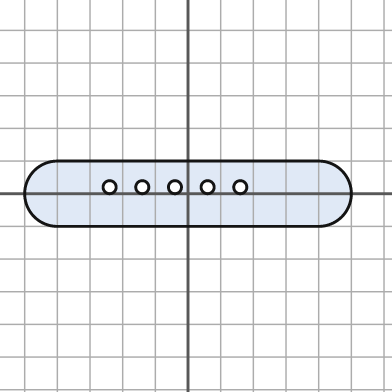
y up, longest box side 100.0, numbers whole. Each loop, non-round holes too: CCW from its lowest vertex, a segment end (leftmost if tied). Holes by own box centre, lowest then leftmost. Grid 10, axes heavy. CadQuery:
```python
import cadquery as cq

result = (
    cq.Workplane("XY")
    .moveTo(-40.0, -10.0)
    .lineTo(40.0, -10.0)
    .threePointArc((50.0, 0.0), (40.0, 10.0))
    .lineTo(-40.0, 10.0)
    .threePointArc((-50.0, 0.0), (-40.0, -10.0))
    .close()
    .moveTo(-24.0, 2.0)
    .circle(2.0)
    .moveTo(-14.0, 2.0)
    .circle(2.0)
    .moveTo(-4.0, 2.0)
    .circle(2.0)
    .moveTo(6.0, 2.0)
    .circle(2.0)
    .moveTo(16.0, 2.0)
    .circle(2.0)
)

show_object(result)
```